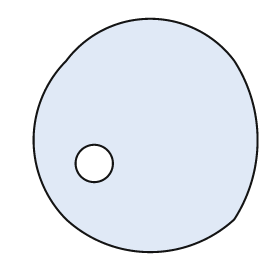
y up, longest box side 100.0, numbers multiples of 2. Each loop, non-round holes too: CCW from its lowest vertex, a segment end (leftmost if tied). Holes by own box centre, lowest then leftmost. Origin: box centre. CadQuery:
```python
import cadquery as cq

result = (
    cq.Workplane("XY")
    .moveTo(-34.0, -36.0)
    .threePointArc((2.0, -50.0), (38.0, -36.0))
    .threePointArc((48.0, -2.0), (38.0, 32.0))
    .threePointArc((2.0, 50.0), (-34.0, 32.0))
    .threePointArc((-48.0, -2.0), (-34.0, -36.0))
    .close()
    .moveTo(-22.0, -12.0)
    .circle(8.0)
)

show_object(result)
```